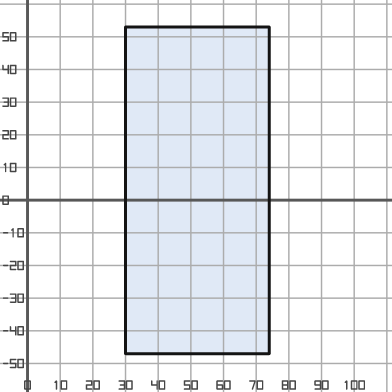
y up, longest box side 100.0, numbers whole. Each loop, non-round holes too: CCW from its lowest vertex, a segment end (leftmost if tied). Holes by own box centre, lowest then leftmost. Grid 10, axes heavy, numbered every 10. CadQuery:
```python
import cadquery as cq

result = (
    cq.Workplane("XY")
    .moveTo(30.0, -47.0)
    .lineTo(74.0, -47.0)
    .lineTo(74.0, 53.0)
    .lineTo(30.0, 53.0)
    .close()
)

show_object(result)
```